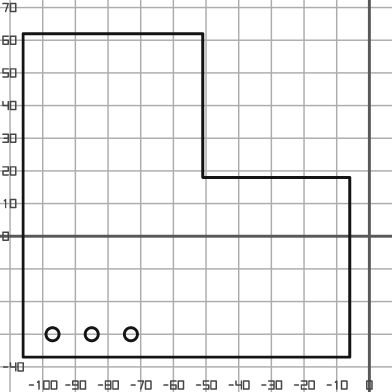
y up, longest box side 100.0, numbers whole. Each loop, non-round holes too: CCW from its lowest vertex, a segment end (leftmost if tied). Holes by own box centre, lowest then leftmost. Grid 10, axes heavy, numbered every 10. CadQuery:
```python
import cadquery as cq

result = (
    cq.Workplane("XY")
    .moveTo(-106.0, -37.0)
    .lineTo(-6.0, -37.0)
    .lineTo(-6.0, 18.0)
    .lineTo(-51.0, 18.0)
    .lineTo(-51.0, 62.0)
    .lineTo(-106.0, 62.0)
    .close()
    .moveTo(-97.0, -30.0)
    .circle(2.0)
    .moveTo(-85.0, -30.0)
    .circle(2.0)
    .moveTo(-73.0, -30.0)
    .circle(2.0)
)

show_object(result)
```